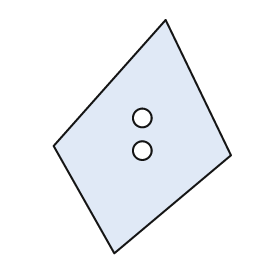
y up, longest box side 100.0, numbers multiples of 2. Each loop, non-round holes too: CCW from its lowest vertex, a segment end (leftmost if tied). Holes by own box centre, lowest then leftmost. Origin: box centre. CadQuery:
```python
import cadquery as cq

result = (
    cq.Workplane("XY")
    .moveTo(-12.0, -50.0)
    .lineTo(38.0, -8.0)
    .lineTo(10.0, 50.0)
    .lineTo(-38.0, -4.0)
    .close()
    .moveTo(0.0, -6.0)
    .circle(4.0)
    .moveTo(0.0, 8.0)
    .circle(4.0)
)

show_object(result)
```